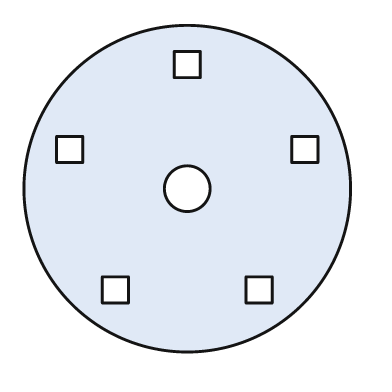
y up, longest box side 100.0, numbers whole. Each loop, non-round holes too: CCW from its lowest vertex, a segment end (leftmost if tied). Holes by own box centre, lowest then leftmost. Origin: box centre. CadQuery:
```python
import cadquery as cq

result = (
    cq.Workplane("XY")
    .moveTo(0.0, 0.0)
    .circle(50.0)
    .moveTo(-26.0, -35.0)
    .lineTo(-18.0, -35.0)
    .lineTo(-18.0, -27.0)
    .lineTo(-26.0, -27.0)
    .close()
    .moveTo(18.0, -35.0)
    .lineTo(26.0, -35.0)
    .lineTo(26.0, -27.0)
    .lineTo(18.0, -27.0)
    .close()
    .moveTo(0.0, 0.0)
    .circle(7.0)
    .moveTo(-40.0, 8.0)
    .lineTo(-32.0, 8.0)
    .lineTo(-32.0, 16.0)
    .lineTo(-40.0, 16.0)
    .close()
    .moveTo(32.0, 8.0)
    .lineTo(40.0, 8.0)
    .lineTo(40.0, 16.0)
    .lineTo(32.0, 16.0)
    .close()
    .moveTo(-4.0, 34.0)
    .lineTo(4.0, 34.0)
    .lineTo(4.0, 42.0)
    .lineTo(-4.0, 42.0)
    .close()
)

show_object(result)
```